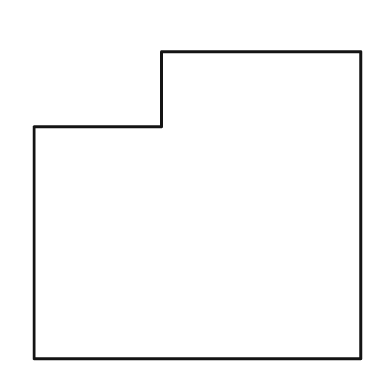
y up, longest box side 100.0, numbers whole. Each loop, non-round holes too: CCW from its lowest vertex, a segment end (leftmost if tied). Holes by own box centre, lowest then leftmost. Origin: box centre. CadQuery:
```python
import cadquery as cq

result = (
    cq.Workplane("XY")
    .moveTo(-50.0, -47.0)
    .lineTo(50.0, -47.0)
    .lineTo(50.0, 47.0)
    .lineTo(-11.0, 47.0)
    .lineTo(-11.0, 24.0)
    .lineTo(-50.0, 24.0)
    .close()
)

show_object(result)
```